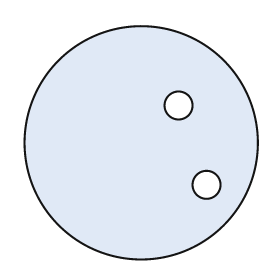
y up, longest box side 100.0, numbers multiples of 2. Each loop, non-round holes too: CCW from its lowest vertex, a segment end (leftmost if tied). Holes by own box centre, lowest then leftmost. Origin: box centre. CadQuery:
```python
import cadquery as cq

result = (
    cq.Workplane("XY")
    .moveTo(0.0, 0.0)
    .circle(50.0)
    .moveTo(28.0, -18.0)
    .circle(6.0)
    .moveTo(16.0, 16.0)
    .circle(6.0)
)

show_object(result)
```